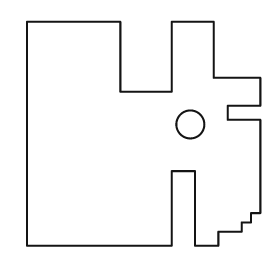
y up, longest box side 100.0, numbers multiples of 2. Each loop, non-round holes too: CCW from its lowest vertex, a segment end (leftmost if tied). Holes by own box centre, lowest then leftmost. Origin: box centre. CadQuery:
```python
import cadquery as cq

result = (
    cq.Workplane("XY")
    .moveTo(-50.0, -48.0)
    .lineTo(12.0, -48.0)
    .lineTo(12.0, -16.0)
    .lineTo(22.0, -16.0)
    .lineTo(22.0, -48.0)
    .lineTo(32.0, -48.0)
    .lineTo(32.0, -42.0)
    .lineTo(42.0, -42.0)
    .lineTo(42.0, -38.0)
    .lineTo(46.0, -38.0)
    .lineTo(46.0, -34.0)
    .lineTo(50.0, -34.0)
    .lineTo(50.0, 6.0)
    .lineTo(36.0, 6.0)
    .lineTo(36.0, 12.0)
    .lineTo(50.0, 12.0)
    .lineTo(50.0, 24.0)
    .lineTo(30.0, 24.0)
    .lineTo(30.0, 48.0)
    .lineTo(12.0, 48.0)
    .lineTo(12.0, 18.0)
    .lineTo(-10.0, 18.0)
    .lineTo(-10.0, 48.0)
    .lineTo(-50.0, 48.0)
    .close()
    .moveTo(20.0, 4.0)
    .circle(6.0)
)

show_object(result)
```